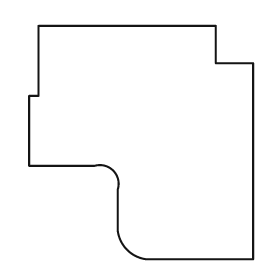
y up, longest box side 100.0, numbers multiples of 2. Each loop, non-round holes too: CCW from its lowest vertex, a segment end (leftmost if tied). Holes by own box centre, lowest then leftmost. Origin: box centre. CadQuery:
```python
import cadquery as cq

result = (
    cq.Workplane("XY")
    .moveTo(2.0, -50.0)
    .lineTo(48.0, -50.0)
    .lineTo(48.0, 34.0)
    .lineTo(32.0, 34.0)
    .lineTo(32.0, 50.0)
    .lineTo(-44.0, 50.0)
    .lineTo(-44.0, 20.0)
    .lineTo(-48.0, 20.0)
    .lineTo(-48.0, -10.0)
    .lineTo(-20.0, -10.0)
    .threePointArc((-12.0, -12.0), (-10.0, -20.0))
    .lineTo(-10.0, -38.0)
    .threePointArc((-6.0, -46.0), (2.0, -50.0))
    .close()
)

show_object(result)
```